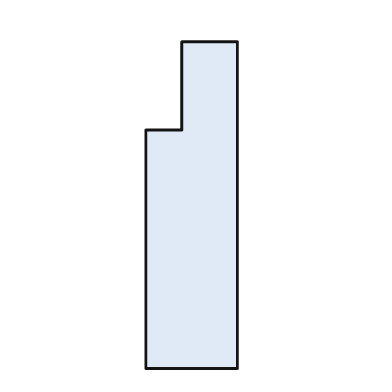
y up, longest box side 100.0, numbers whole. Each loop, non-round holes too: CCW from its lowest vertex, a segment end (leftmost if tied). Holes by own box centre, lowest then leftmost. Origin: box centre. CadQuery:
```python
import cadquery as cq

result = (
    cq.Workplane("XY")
    .moveTo(-14.0, -50.0)
    .lineTo(14.0, -50.0)
    .lineTo(14.0, 50.0)
    .lineTo(-3.0, 50.0)
    .lineTo(-3.0, 23.0)
    .lineTo(-14.0, 23.0)
    .close()
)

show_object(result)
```